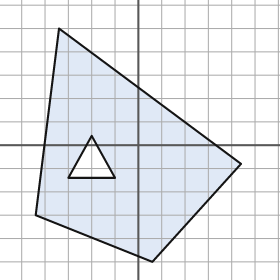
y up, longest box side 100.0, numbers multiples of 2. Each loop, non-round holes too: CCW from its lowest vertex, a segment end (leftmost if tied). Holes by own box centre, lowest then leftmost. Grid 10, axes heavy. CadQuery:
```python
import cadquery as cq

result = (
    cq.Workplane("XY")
    .moveTo(6.0, -50.0)
    .lineTo(44.0, -8.0)
    .lineTo(-34.0, 50.0)
    .lineTo(-44.0, -30.0)
    .close()
    .moveTo(-30.0, -14.0)
    .lineTo(-10.0, -14.0)
    .lineTo(-20.0, 4.0)
    .close()
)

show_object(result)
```